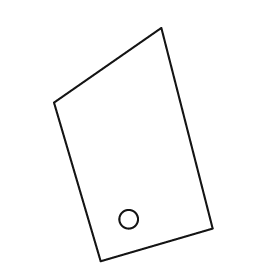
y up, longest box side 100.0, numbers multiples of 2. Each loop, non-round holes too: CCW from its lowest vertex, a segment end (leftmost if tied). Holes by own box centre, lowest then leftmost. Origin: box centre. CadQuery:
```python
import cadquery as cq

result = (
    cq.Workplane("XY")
    .moveTo(-14.0, -50.0)
    .lineTo(34.0, -36.0)
    .lineTo(12.0, 50.0)
    .lineTo(-34.0, 18.0)
    .close()
    .moveTo(-2.0, -32.0)
    .circle(4.0)
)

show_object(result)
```